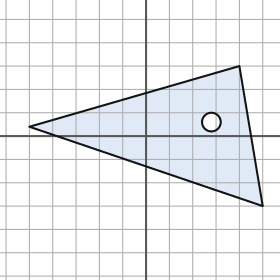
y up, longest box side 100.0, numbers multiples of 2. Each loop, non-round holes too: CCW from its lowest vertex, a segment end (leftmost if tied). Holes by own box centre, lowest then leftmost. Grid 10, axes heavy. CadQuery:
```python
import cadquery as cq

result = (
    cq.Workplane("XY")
    .moveTo(50.0, -30.0)
    .lineTo(40.0, 30.0)
    .lineTo(-50.0, 4.0)
    .close()
    .moveTo(28.0, 6.0)
    .circle(4.0)
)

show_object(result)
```